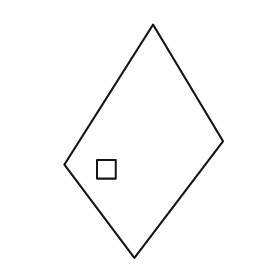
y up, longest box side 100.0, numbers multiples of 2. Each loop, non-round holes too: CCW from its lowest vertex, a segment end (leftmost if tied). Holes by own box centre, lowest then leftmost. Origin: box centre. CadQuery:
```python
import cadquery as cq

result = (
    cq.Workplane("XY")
    .moveTo(-4.0, -50.0)
    .lineTo(34.0, 0.0)
    .lineTo(4.0, 50.0)
    .lineTo(-34.0, -10.0)
    .close()
    .moveTo(-20.0, -16.0)
    .lineTo(-12.0, -16.0)
    .lineTo(-12.0, -8.0)
    .lineTo(-20.0, -8.0)
    .close()
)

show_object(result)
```